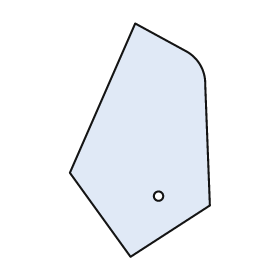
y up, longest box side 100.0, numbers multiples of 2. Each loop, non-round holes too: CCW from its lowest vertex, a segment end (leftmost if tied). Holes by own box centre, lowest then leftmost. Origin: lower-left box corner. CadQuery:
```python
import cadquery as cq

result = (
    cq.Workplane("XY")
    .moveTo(26.0, 0.0)
    .lineTo(60.0, 22.0)
    .lineTo(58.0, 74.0)
    .threePointArc((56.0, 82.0), (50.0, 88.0))
    .lineTo(28.0, 100.0)
    .lineTo(0.0, 36.0)
    .close()
    .moveTo(38.0, 26.0)
    .circle(2.0)
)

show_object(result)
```